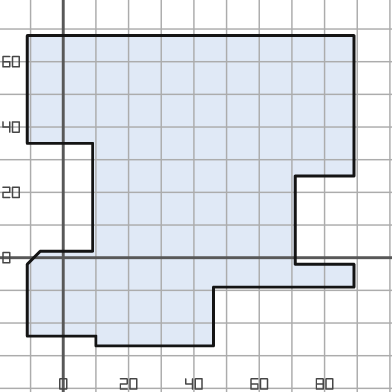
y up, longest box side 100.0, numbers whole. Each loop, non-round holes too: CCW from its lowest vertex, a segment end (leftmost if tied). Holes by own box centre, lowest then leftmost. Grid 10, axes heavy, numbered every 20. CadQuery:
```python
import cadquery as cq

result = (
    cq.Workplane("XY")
    .moveTo(10.0, -27.0)
    .lineTo(46.0, -27.0)
    .lineTo(46.0, -9.0)
    .lineTo(89.0, -9.0)
    .lineTo(89.0, -2.0)
    .lineTo(71.0, -2.0)
    .lineTo(71.0, 25.0)
    .lineTo(89.0, 25.0)
    .lineTo(89.0, 68.0)
    .lineTo(-11.0, 68.0)
    .lineTo(-11.0, 35.0)
    .lineTo(9.0, 35.0)
    .lineTo(9.0, 2.0)
    .lineTo(-7.0, 2.0)
    .lineTo(-11.0, -2.0)
    .lineTo(-11.0, -24.0)
    .lineTo(10.0, -24.0)
    .close()
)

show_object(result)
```